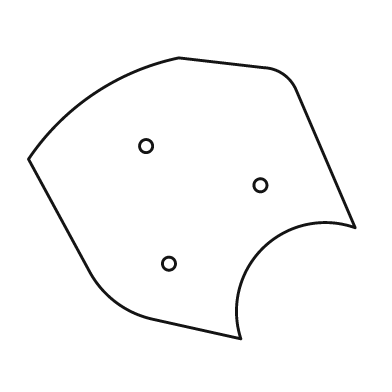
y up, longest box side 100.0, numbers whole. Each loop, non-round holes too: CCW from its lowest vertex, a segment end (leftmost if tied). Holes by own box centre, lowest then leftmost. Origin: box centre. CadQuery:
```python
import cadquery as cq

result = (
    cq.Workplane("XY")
    .moveTo(15.0, -43.0)
    .threePointArc((22.0, -15.0), (50.0, -9.0))
    .lineTo(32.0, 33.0)
    .threePointArc((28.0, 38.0), (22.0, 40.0))
    .lineTo(-4.0, 43.0)
    .threePointArc((-30.0, 32.0), (-50.0, 12.0))
    .lineTo(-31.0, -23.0)
    .threePointArc((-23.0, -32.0), (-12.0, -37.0))
    .close()
    .moveTo(-7.0, -20.0)
    .circle(2.0)
    .moveTo(21.0, 4.0)
    .circle(2.0)
    .moveTo(-14.0, 16.0)
    .circle(2.0)
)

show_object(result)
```